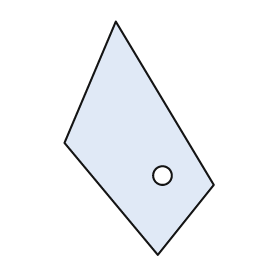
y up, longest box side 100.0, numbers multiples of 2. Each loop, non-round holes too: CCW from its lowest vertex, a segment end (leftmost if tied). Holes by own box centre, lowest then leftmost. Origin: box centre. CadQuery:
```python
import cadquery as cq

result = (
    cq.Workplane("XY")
    .moveTo(8.0, -50.0)
    .lineTo(32.0, -20.0)
    .lineTo(-10.0, 50.0)
    .lineTo(-32.0, -2.0)
    .close()
    .moveTo(10.0, -16.0)
    .circle(4.0)
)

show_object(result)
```